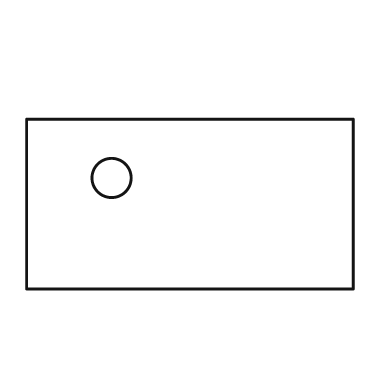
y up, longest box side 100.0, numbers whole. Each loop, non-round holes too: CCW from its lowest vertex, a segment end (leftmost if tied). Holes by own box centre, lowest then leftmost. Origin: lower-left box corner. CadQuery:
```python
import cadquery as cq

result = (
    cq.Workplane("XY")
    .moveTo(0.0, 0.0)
    .lineTo(100.0, 0.0)
    .lineTo(100.0, 52.0)
    .lineTo(0.0, 52.0)
    .close()
    .moveTo(26.0, 34.0)
    .circle(6.0)
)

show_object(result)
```